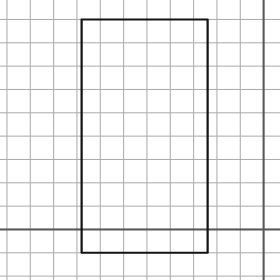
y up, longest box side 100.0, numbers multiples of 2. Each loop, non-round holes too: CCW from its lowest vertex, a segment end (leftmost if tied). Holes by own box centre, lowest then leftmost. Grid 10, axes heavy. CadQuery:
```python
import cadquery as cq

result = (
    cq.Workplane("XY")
    .moveTo(-78.0, -10.0)
    .lineTo(-24.0, -10.0)
    .lineTo(-24.0, 90.0)
    .lineTo(-78.0, 90.0)
    .close()
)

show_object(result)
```